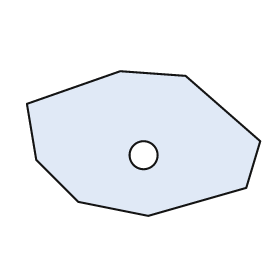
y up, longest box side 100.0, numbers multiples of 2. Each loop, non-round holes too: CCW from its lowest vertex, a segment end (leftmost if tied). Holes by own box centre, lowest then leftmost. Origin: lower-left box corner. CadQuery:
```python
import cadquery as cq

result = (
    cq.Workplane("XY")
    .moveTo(52.0, 0.0)
    .lineTo(94.0, 12.0)
    .lineTo(100.0, 32.0)
    .lineTo(68.0, 60.0)
    .lineTo(40.0, 62.0)
    .lineTo(0.0, 48.0)
    .lineTo(4.0, 24.0)
    .lineTo(22.0, 6.0)
    .close()
    .moveTo(50.0, 26.0)
    .circle(6.0)
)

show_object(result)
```